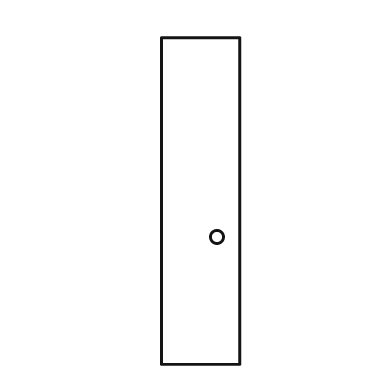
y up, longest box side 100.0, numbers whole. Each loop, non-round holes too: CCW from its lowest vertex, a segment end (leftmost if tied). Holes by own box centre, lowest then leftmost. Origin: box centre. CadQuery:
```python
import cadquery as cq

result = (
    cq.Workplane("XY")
    .moveTo(-12.0, -50.0)
    .lineTo(12.0, -50.0)
    .lineTo(12.0, 50.0)
    .lineTo(-12.0, 50.0)
    .close()
    .moveTo(5.0, -11.0)
    .circle(2.0)
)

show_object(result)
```